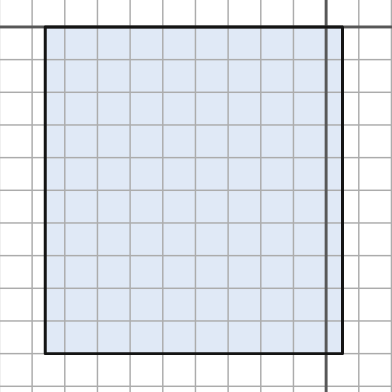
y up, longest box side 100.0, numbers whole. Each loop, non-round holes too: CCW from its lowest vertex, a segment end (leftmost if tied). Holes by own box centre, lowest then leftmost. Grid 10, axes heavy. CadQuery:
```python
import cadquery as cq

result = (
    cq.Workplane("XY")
    .moveTo(-86.0, -100.0)
    .lineTo(5.0, -100.0)
    .lineTo(5.0, 0.0)
    .lineTo(-86.0, 0.0)
    .close()
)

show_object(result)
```